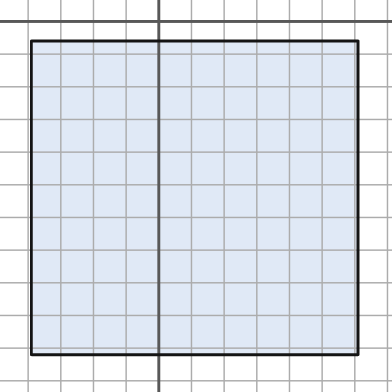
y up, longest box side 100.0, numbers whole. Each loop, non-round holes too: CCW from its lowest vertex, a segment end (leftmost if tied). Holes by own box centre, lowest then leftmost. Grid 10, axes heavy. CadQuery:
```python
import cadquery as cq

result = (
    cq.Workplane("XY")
    .moveTo(-39.0, -102.0)
    .lineTo(61.0, -102.0)
    .lineTo(61.0, -6.0)
    .lineTo(-39.0, -6.0)
    .close()
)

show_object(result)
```